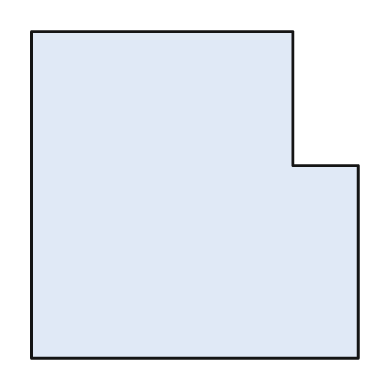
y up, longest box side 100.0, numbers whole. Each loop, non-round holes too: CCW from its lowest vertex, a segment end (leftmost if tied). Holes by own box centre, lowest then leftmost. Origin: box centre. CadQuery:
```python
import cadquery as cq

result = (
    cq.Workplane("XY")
    .moveTo(-50.0, -50.0)
    .lineTo(50.0, -50.0)
    .lineTo(50.0, 9.0)
    .lineTo(30.0, 9.0)
    .lineTo(30.0, 50.0)
    .lineTo(-50.0, 50.0)
    .close()
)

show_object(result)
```